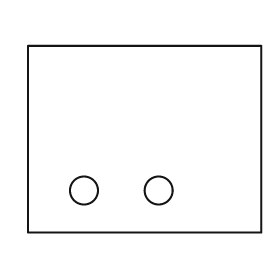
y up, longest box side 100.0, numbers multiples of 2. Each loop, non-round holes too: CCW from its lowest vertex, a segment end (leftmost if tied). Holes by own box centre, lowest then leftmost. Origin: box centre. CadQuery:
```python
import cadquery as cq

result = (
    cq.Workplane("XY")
    .moveTo(-50.0, -40.0)
    .lineTo(50.0, -40.0)
    .lineTo(50.0, 40.0)
    .lineTo(-50.0, 40.0)
    .close()
    .moveTo(-26.0, -22.0)
    .circle(6.0)
    .moveTo(6.0, -22.0)
    .circle(6.0)
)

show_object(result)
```